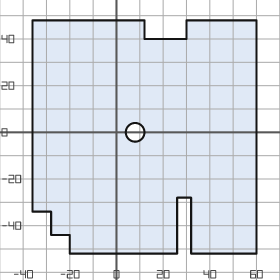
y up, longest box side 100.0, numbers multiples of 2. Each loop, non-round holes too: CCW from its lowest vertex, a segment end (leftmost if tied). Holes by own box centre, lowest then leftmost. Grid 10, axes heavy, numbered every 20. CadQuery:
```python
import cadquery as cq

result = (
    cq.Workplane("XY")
    .moveTo(-20.0, -52.0)
    .lineTo(26.0, -52.0)
    .lineTo(26.0, -28.0)
    .lineTo(32.0, -28.0)
    .lineTo(32.0, -52.0)
    .lineTo(60.0, -52.0)
    .lineTo(60.0, 48.0)
    .lineTo(30.0, 48.0)
    .lineTo(30.0, 40.0)
    .lineTo(12.0, 40.0)
    .lineTo(12.0, 48.0)
    .lineTo(-36.0, 48.0)
    .lineTo(-36.0, -34.0)
    .lineTo(-28.0, -34.0)
    .lineTo(-28.0, -44.0)
    .lineTo(-20.0, -44.0)
    .close()
    .moveTo(8.0, 0.0)
    .circle(4.0)
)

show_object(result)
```